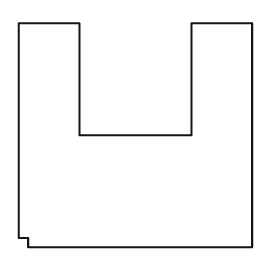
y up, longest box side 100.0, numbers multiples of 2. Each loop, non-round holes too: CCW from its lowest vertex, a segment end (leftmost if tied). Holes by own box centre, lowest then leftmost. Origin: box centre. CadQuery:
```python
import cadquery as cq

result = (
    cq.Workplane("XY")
    .moveTo(-46.0, -48.0)
    .lineTo(50.0, -48.0)
    .lineTo(50.0, 48.0)
    .lineTo(24.0, 48.0)
    .lineTo(24.0, 0.0)
    .lineTo(-24.0, 0.0)
    .lineTo(-24.0, 48.0)
    .lineTo(-50.0, 48.0)
    .lineTo(-50.0, -44.0)
    .lineTo(-46.0, -44.0)
    .close()
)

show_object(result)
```